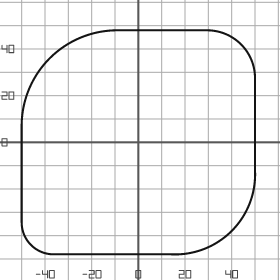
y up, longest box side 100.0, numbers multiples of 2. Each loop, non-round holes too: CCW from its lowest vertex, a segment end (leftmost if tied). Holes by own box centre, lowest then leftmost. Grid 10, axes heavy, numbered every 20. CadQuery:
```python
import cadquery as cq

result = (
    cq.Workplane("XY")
    .moveTo(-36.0, -48.0)
    .lineTo(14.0, -48.0)
    .threePointArc((40.0, -38.0), (50.0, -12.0))
    .lineTo(50.0, 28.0)
    .threePointArc((44.0, 42.0), (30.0, 48.0))
    .lineTo(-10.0, 48.0)
    .threePointArc((-38.0, 36.0), (-50.0, 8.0))
    .lineTo(-50.0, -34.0)
    .threePointArc((-46.0, -44.0), (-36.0, -48.0))
    .close()
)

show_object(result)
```